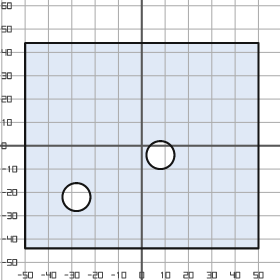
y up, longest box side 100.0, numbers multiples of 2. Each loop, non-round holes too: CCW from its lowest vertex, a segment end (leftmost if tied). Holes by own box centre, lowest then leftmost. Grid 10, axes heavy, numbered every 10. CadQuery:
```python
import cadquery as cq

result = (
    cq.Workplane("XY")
    .moveTo(-50.0, -44.0)
    .lineTo(50.0, -44.0)
    .lineTo(50.0, 44.0)
    .lineTo(-50.0, 44.0)
    .close()
    .moveTo(-28.0, -22.0)
    .circle(6.0)
    .moveTo(8.0, -4.0)
    .circle(6.0)
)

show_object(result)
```